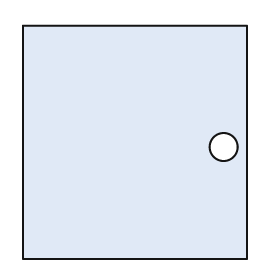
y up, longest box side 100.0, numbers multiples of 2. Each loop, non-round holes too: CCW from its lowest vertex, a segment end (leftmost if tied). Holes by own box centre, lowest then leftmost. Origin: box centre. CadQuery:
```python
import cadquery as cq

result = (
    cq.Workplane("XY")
    .moveTo(-48.0, -50.0)
    .lineTo(48.0, -50.0)
    .lineTo(48.0, 50.0)
    .lineTo(-48.0, 50.0)
    .close()
    .moveTo(38.0, -2.0)
    .circle(6.0)
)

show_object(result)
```